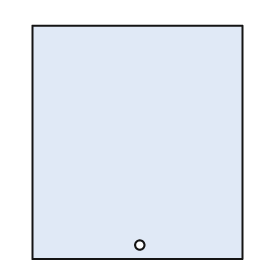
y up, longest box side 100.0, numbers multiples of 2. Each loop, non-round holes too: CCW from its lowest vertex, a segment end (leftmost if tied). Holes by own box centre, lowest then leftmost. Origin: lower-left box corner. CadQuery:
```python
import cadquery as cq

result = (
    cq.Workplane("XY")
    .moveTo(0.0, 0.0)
    .lineTo(90.0, 0.0)
    .lineTo(90.0, 100.0)
    .lineTo(0.0, 100.0)
    .close()
    .moveTo(46.0, 6.0)
    .circle(2.0)
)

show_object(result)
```